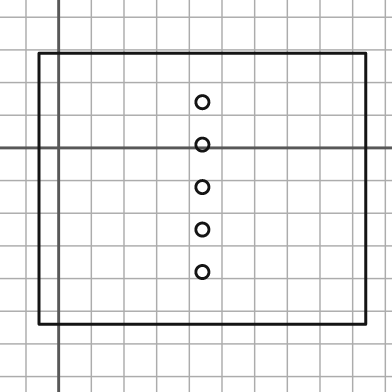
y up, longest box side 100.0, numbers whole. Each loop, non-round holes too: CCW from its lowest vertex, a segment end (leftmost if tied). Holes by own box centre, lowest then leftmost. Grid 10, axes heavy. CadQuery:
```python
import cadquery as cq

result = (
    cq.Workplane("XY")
    .moveTo(-6.0, -54.0)
    .lineTo(94.0, -54.0)
    .lineTo(94.0, 29.0)
    .lineTo(-6.0, 29.0)
    .close()
    .moveTo(44.0, -38.0)
    .circle(2.0)
    .moveTo(44.0, -25.0)
    .circle(2.0)
    .moveTo(44.0, -12.0)
    .circle(2.0)
    .moveTo(44.0, 1.0)
    .circle(2.0)
    .moveTo(44.0, 14.0)
    .circle(2.0)
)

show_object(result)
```